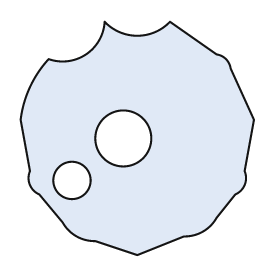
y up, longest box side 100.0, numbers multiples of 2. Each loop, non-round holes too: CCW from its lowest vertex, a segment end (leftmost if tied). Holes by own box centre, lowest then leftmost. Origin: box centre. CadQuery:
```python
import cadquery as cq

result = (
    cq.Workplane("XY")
    .moveTo(0.0, -50.0)
    .lineTo(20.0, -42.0)
    .threePointArc((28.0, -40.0), (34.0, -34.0))
    .lineTo(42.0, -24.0)
    .threePointArc((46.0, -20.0), (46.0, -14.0))
    .lineTo(50.0, 8.0)
    .lineTo(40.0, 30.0)
    .threePointArc((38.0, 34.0), (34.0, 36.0))
    .lineTo(14.0, 50.0)
    .threePointArc((0.0, 44.0), (-14.0, 50.0))
    .threePointArc((-22.0, 36.0), (-38.0, 34.0))
    .threePointArc((-46.0, 22.0), (-50.0, 8.0))
    .lineTo(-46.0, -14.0)
    .threePointArc((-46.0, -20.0), (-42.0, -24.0))
    .lineTo(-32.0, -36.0)
    .threePointArc((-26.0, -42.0), (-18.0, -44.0))
    .close()
    .moveTo(-28.0, -18.0)
    .circle(8.0)
    .moveTo(-6.0, 0.0)
    .circle(12.0)
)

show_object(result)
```